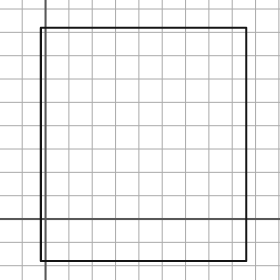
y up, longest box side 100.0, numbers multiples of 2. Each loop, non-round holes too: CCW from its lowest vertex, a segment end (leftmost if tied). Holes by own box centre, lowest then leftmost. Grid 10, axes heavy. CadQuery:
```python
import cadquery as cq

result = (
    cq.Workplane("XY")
    .moveTo(-2.0, -18.0)
    .lineTo(86.0, -18.0)
    .lineTo(86.0, 82.0)
    .lineTo(-2.0, 82.0)
    .close()
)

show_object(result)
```